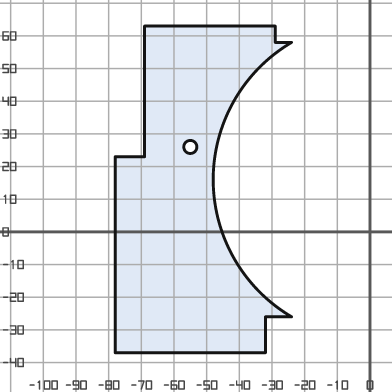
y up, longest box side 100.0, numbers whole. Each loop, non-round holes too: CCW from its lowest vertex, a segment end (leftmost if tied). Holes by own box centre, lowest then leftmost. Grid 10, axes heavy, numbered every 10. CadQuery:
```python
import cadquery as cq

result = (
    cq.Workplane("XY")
    .moveTo(-78.0, -37.0)
    .lineTo(-32.0, -37.0)
    .lineTo(-32.0, -26.0)
    .lineTo(-24.0, -26.0)
    .threePointArc((-48.0, 16.0), (-24.0, 58.0))
    .lineTo(-29.0, 58.0)
    .lineTo(-29.0, 63.0)
    .lineTo(-69.0, 63.0)
    .lineTo(-69.0, 23.0)
    .lineTo(-78.0, 23.0)
    .close()
    .moveTo(-55.0, 26.0)
    .circle(2.0)
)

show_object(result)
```